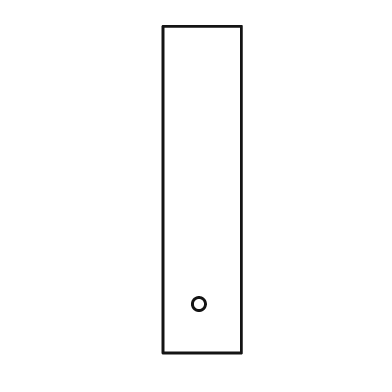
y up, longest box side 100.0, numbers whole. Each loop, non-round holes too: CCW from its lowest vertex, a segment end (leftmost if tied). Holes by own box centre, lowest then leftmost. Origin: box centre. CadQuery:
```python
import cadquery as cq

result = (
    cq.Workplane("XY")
    .moveTo(-12.0, -50.0)
    .lineTo(12.0, -50.0)
    .lineTo(12.0, 50.0)
    .lineTo(-12.0, 50.0)
    .close()
    .moveTo(-1.0, -35.0)
    .circle(2.0)
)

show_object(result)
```